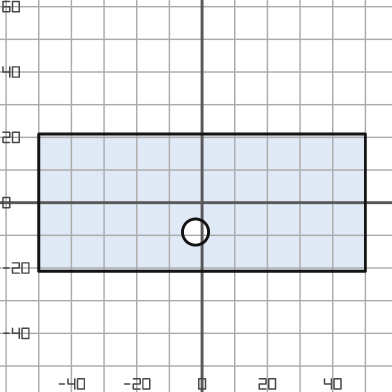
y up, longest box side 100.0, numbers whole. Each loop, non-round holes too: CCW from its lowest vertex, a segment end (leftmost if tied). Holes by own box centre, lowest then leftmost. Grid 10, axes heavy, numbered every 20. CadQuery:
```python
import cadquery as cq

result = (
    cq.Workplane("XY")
    .moveTo(-50.0, -21.0)
    .lineTo(50.0, -21.0)
    .lineTo(50.0, 21.0)
    .lineTo(-50.0, 21.0)
    .close()
    .moveTo(-2.0, -9.0)
    .circle(4.0)
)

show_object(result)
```